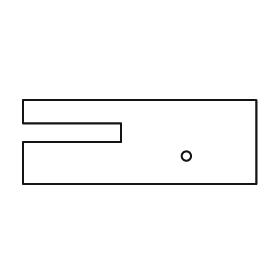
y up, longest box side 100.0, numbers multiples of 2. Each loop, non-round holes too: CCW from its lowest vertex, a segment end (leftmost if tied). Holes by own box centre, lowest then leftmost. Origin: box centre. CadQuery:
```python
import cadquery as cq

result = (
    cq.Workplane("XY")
    .moveTo(-50.0, -18.0)
    .lineTo(50.0, -18.0)
    .lineTo(50.0, 18.0)
    .lineTo(-50.0, 18.0)
    .lineTo(-50.0, 8.0)
    .lineTo(-8.0, 8.0)
    .lineTo(-8.0, 0.0)
    .lineTo(-50.0, 0.0)
    .close()
    .moveTo(20.0, -6.0)
    .circle(2.0)
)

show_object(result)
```